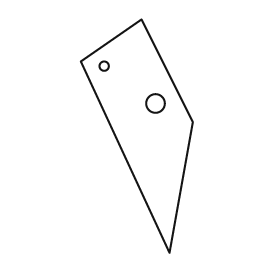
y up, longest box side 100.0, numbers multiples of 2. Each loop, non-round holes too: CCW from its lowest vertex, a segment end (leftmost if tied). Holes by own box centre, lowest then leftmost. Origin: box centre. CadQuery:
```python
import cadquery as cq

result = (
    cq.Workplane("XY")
    .moveTo(14.0, -50.0)
    .lineTo(24.0, 6.0)
    .lineTo(2.0, 50.0)
    .lineTo(-24.0, 32.0)
    .close()
    .moveTo(8.0, 14.0)
    .circle(4.0)
    .moveTo(-14.0, 30.0)
    .circle(2.0)
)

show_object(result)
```